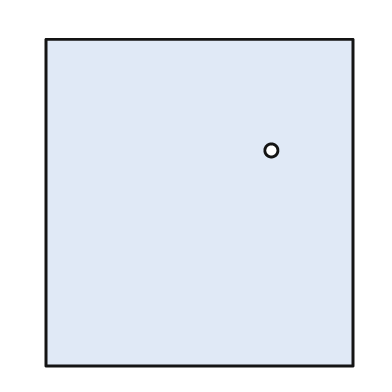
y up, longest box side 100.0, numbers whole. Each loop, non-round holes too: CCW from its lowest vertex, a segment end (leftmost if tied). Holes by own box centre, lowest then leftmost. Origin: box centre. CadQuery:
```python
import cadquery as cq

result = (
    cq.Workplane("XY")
    .moveTo(-47.0, -50.0)
    .lineTo(47.0, -50.0)
    .lineTo(47.0, 50.0)
    .lineTo(-47.0, 50.0)
    .close()
    .moveTo(22.0, 16.0)
    .circle(2.0)
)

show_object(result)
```